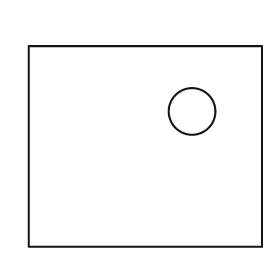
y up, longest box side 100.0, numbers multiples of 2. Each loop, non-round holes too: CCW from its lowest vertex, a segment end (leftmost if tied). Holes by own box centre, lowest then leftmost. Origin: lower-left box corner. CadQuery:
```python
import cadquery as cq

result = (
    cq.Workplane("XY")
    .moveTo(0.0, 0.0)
    .lineTo(100.0, 0.0)
    .lineTo(100.0, 86.0)
    .lineTo(0.0, 86.0)
    .close()
    .moveTo(70.0, 58.0)
    .circle(10.0)
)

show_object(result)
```